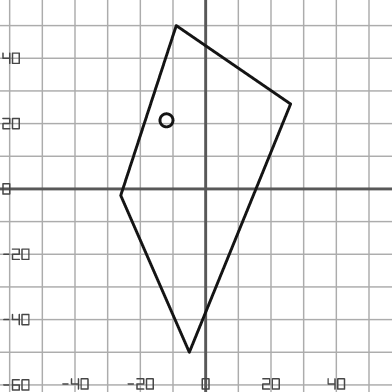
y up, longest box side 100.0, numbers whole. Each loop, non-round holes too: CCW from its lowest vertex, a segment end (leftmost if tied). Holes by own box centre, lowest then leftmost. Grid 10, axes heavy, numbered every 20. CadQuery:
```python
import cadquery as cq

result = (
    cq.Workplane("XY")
    .moveTo(-5.0, -50.0)
    .lineTo(26.0, 26.0)
    .lineTo(-9.0, 50.0)
    .lineTo(-26.0, -2.0)
    .close()
    .moveTo(-12.0, 21.0)
    .circle(2.0)
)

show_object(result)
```